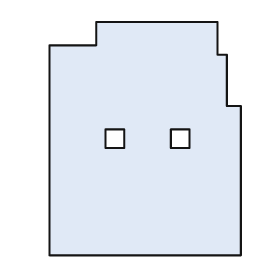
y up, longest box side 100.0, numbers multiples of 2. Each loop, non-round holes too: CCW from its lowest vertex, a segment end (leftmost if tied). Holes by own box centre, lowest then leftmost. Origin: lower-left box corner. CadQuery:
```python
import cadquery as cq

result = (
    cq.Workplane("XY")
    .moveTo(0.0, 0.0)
    .lineTo(82.0, 0.0)
    .lineTo(82.0, 64.0)
    .lineTo(76.0, 64.0)
    .lineTo(76.0, 86.0)
    .lineTo(72.0, 86.0)
    .lineTo(72.0, 100.0)
    .lineTo(20.0, 100.0)
    .lineTo(20.0, 90.0)
    .lineTo(0.0, 90.0)
    .close()
    .moveTo(24.0, 46.0)
    .lineTo(32.0, 46.0)
    .lineTo(32.0, 54.0)
    .lineTo(24.0, 54.0)
    .close()
    .moveTo(52.0, 46.0)
    .lineTo(60.0, 46.0)
    .lineTo(60.0, 54.0)
    .lineTo(52.0, 54.0)
    .close()
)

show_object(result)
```